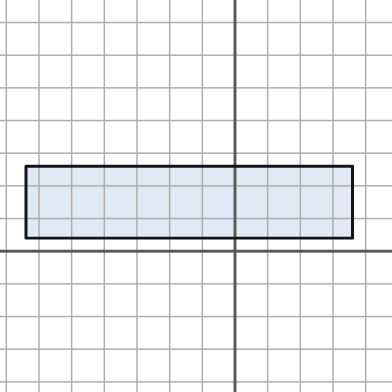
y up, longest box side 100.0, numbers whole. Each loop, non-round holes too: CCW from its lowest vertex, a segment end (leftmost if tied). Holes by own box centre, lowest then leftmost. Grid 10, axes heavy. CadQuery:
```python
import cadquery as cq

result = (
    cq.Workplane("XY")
    .moveTo(-64.0, 4.0)
    .lineTo(36.0, 4.0)
    .lineTo(36.0, 26.0)
    .lineTo(-64.0, 26.0)
    .close()
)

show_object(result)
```